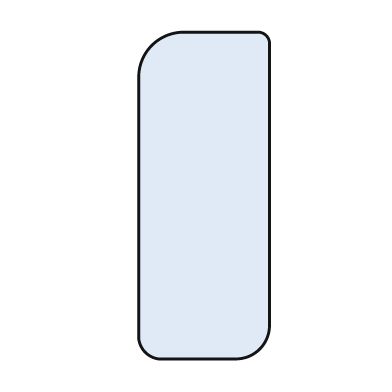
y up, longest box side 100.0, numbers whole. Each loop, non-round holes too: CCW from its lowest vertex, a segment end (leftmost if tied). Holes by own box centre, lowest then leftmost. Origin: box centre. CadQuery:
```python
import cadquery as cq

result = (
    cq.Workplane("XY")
    .moveTo(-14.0, -50.0)
    .lineTo(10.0, -50.0)
    .threePointArc((17.0, -47.0), (20.0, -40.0))
    .lineTo(20.0, 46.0)
    .threePointArc((19.0, 49.0), (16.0, 50.0))
    .lineTo(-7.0, 50.0)
    .threePointArc((-16.0, 46.0), (-20.0, 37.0))
    .lineTo(-20.0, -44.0)
    .threePointArc((-18.0, -48.0), (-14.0, -50.0))
    .close()
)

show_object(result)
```